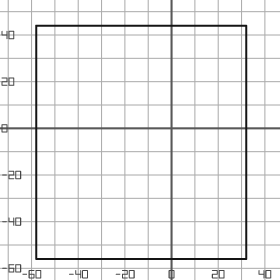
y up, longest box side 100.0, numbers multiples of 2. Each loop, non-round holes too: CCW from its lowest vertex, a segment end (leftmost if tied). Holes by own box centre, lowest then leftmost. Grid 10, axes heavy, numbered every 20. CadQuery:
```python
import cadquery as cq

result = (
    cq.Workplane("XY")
    .moveTo(-58.0, -56.0)
    .lineTo(32.0, -56.0)
    .lineTo(32.0, 44.0)
    .lineTo(-58.0, 44.0)
    .close()
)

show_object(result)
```